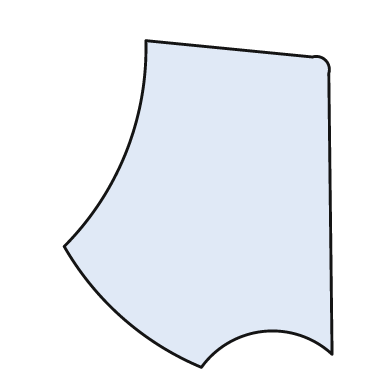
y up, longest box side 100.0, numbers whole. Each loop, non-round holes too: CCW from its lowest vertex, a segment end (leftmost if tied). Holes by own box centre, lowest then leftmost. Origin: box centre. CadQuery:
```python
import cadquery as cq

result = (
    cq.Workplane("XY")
    .moveTo(1.0, -50.0)
    .threePointArc((20.0, -39.0), (41.0, -46.0))
    .lineTo(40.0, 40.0)
    .threePointArc((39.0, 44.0), (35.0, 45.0))
    .lineTo(-16.0, 50.0)
    .threePointArc((-22.0, 16.0), (-41.0, -13.0))
    .threePointArc((-23.0, -35.0), (1.0, -50.0))
    .close()
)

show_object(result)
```